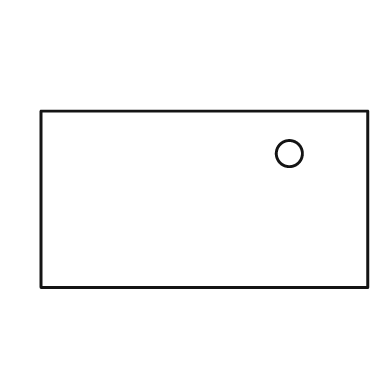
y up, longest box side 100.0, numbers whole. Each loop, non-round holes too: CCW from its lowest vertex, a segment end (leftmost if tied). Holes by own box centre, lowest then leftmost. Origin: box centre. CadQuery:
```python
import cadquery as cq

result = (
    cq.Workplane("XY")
    .moveTo(-50.0, -27.0)
    .lineTo(50.0, -27.0)
    .lineTo(50.0, 27.0)
    .lineTo(-50.0, 27.0)
    .close()
    .moveTo(26.0, 14.0)
    .circle(4.0)
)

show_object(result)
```